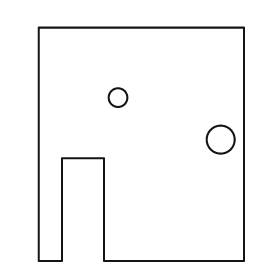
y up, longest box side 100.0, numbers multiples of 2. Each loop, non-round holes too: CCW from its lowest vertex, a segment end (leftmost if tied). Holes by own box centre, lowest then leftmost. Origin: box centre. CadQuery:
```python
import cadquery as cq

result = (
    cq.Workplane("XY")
    .moveTo(-44.0, -50.0)
    .lineTo(-34.0, -50.0)
    .lineTo(-34.0, -6.0)
    .lineTo(-16.0, -6.0)
    .lineTo(-16.0, -50.0)
    .lineTo(44.0, -50.0)
    .lineTo(44.0, 50.0)
    .lineTo(-44.0, 50.0)
    .close()
    .moveTo(34.0, 2.0)
    .circle(6.0)
    .moveTo(-10.0, 20.0)
    .circle(4.0)
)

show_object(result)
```